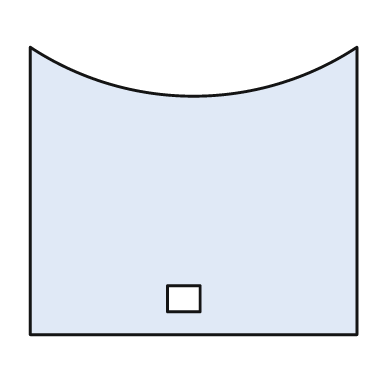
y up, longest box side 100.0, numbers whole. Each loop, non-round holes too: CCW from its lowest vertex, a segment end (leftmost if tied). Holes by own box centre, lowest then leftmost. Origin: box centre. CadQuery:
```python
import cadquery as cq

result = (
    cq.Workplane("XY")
    .moveTo(-50.0, -44.0)
    .lineTo(50.0, -44.0)
    .lineTo(50.0, 44.0)
    .threePointArc((0.0, 29.0), (-50.0, 44.0))
    .close()
    .moveTo(-8.0, -37.0)
    .lineTo(2.0, -37.0)
    .lineTo(2.0, -29.0)
    .lineTo(-8.0, -29.0)
    .close()
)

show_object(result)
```